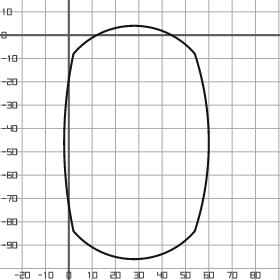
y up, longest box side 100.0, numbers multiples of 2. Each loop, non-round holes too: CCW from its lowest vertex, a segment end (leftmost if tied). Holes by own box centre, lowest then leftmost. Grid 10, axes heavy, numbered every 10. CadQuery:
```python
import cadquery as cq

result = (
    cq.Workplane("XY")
    .moveTo(2.0, -84.0)
    .threePointArc((28.0, -96.0), (54.0, -84.0))
    .threePointArc((60.0, -46.0), (54.0, -8.0))
    .threePointArc((28.0, 4.0), (2.0, -8.0))
    .threePointArc((-2.0, -46.0), (2.0, -84.0))
    .close()
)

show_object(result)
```